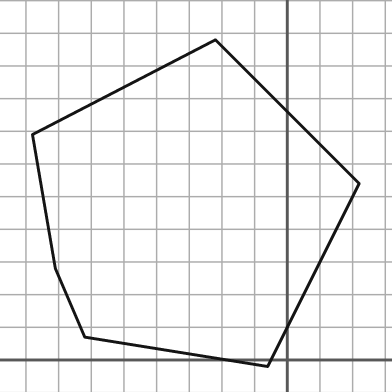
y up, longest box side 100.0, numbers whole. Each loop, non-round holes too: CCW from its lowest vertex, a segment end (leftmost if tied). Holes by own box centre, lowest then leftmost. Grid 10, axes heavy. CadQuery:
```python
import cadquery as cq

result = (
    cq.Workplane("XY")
    .moveTo(-6.0, -2.0)
    .lineTo(22.0, 54.0)
    .lineTo(-22.0, 98.0)
    .lineTo(-78.0, 69.0)
    .lineTo(-71.0, 28.0)
    .lineTo(-62.0, 7.0)
    .close()
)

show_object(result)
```